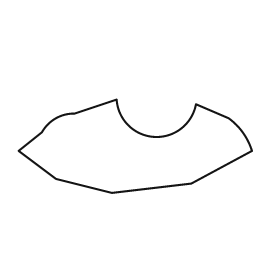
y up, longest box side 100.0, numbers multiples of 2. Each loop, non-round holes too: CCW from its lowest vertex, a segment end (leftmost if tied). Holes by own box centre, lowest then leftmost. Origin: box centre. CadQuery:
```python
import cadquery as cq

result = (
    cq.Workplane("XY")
    .moveTo(-10.0, -20.0)
    .lineTo(24.0, -16.0)
    .lineTo(50.0, -2.0)
    .threePointArc((46.0, 6.0), (40.0, 12.0))
    .lineTo(26.0, 18.0)
    .threePointArc((8.0, 4.0), (-8.0, 20.0))
    .lineTo(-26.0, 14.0)
    .threePointArc((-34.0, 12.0), (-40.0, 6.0))
    .lineTo(-50.0, -2.0)
    .lineTo(-34.0, -14.0)
    .close()
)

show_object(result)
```